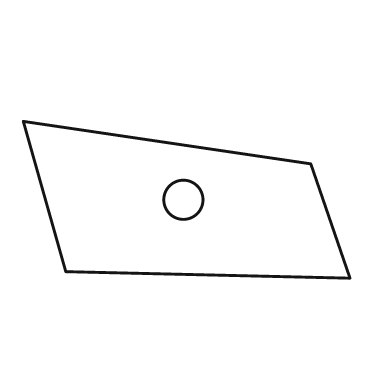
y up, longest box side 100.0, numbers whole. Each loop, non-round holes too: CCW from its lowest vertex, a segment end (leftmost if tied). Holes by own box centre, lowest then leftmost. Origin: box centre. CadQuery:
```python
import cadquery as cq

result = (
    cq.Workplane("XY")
    .moveTo(50.0, -24.0)
    .lineTo(38.0, 11.0)
    .lineTo(-50.0, 24.0)
    .lineTo(-37.0, -22.0)
    .close()
    .moveTo(-1.0, 0.0)
    .circle(6.0)
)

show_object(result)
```